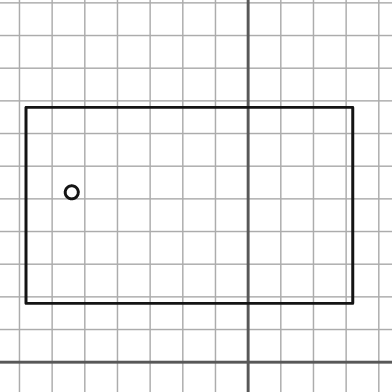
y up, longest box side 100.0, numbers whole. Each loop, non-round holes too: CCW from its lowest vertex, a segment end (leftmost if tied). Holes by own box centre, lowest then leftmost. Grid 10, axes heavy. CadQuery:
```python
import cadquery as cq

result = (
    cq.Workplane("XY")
    .moveTo(-68.0, 18.0)
    .lineTo(32.0, 18.0)
    .lineTo(32.0, 78.0)
    .lineTo(-68.0, 78.0)
    .close()
    .moveTo(-54.0, 52.0)
    .circle(2.0)
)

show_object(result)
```